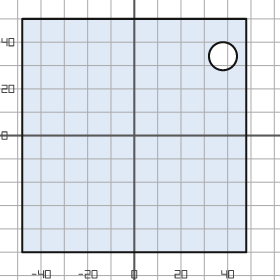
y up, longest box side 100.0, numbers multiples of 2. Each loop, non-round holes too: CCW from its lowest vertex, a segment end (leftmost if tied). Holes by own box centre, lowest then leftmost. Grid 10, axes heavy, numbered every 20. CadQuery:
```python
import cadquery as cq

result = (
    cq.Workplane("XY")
    .moveTo(-48.0, -50.0)
    .lineTo(48.0, -50.0)
    .lineTo(48.0, 50.0)
    .lineTo(-48.0, 50.0)
    .close()
    .moveTo(38.0, 34.0)
    .circle(6.0)
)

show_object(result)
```